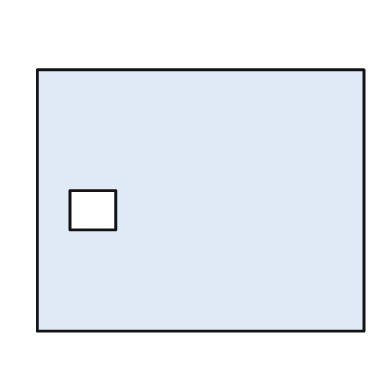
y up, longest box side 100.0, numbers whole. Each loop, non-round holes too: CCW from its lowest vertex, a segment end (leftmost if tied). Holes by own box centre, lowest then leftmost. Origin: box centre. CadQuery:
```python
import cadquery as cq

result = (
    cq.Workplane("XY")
    .moveTo(-50.0, -40.0)
    .lineTo(50.0, -40.0)
    .lineTo(50.0, 40.0)
    .lineTo(-50.0, 40.0)
    .close()
    .moveTo(-40.0, -9.0)
    .lineTo(-26.0, -9.0)
    .lineTo(-26.0, 3.0)
    .lineTo(-40.0, 3.0)
    .close()
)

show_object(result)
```